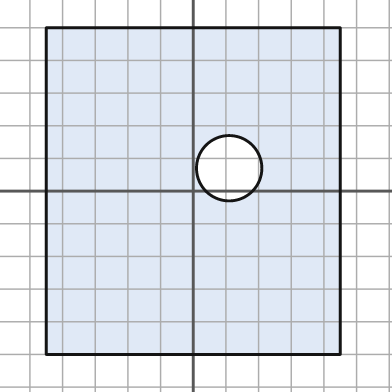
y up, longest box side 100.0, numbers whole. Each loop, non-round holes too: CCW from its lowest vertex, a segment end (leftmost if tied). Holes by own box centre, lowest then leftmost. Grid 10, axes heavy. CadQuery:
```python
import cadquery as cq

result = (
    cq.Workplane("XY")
    .moveTo(-45.0, -50.0)
    .lineTo(45.0, -50.0)
    .lineTo(45.0, 50.0)
    .lineTo(-45.0, 50.0)
    .close()
    .moveTo(11.0, 7.0)
    .circle(10.0)
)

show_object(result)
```